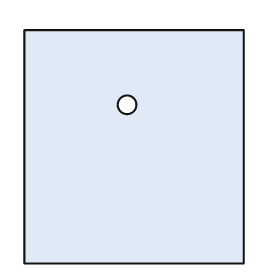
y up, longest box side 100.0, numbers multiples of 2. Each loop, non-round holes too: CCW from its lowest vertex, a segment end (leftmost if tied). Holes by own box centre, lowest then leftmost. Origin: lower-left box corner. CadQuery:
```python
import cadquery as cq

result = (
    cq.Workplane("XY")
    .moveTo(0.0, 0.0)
    .lineTo(94.0, 0.0)
    .lineTo(94.0, 100.0)
    .lineTo(0.0, 100.0)
    .close()
    .moveTo(44.0, 68.0)
    .circle(4.0)
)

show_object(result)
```